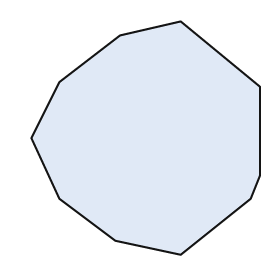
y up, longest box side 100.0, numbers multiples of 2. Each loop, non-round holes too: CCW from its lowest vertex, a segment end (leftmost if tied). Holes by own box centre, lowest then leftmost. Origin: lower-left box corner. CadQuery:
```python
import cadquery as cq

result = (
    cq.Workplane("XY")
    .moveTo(64.0, 0.0)
    .lineTo(94.0, 24.0)
    .lineTo(98.0, 34.0)
    .lineTo(98.0, 72.0)
    .lineTo(64.0, 100.0)
    .lineTo(38.0, 94.0)
    .lineTo(12.0, 74.0)
    .lineTo(0.0, 50.0)
    .lineTo(12.0, 24.0)
    .lineTo(36.0, 6.0)
    .close()
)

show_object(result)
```